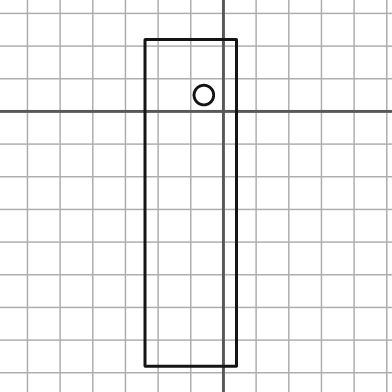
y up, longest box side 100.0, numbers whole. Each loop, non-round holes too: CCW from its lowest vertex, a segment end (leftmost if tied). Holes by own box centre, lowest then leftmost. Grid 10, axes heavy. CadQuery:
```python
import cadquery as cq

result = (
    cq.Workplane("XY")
    .moveTo(-24.0, -78.0)
    .lineTo(4.0, -78.0)
    .lineTo(4.0, 22.0)
    .lineTo(-24.0, 22.0)
    .close()
    .moveTo(-6.0, 5.0)
    .circle(3.0)
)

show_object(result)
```